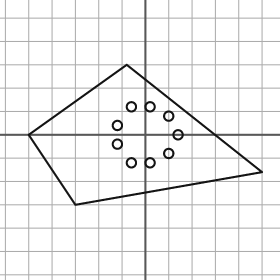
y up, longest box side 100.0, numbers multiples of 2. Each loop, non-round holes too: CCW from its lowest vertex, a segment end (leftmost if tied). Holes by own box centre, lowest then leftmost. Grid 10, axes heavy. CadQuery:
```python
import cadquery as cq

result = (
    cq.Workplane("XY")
    .moveTo(-30.0, -30.0)
    .lineTo(50.0, -16.0)
    .lineTo(-8.0, 30.0)
    .lineTo(-50.0, 0.0)
    .close()
    .moveTo(-6.0, -12.0)
    .circle(2.0)
    .moveTo(2.0, -12.0)
    .circle(2.0)
    .moveTo(10.0, -8.0)
    .circle(2.0)
    .moveTo(-12.0, -4.0)
    .circle(2.0)
    .moveTo(14.0, 0.0)
    .circle(2.0)
    .moveTo(-12.0, 4.0)
    .circle(2.0)
    .moveTo(10.0, 8.0)
    .circle(2.0)
    .moveTo(-6.0, 12.0)
    .circle(2.0)
    .moveTo(2.0, 12.0)
    .circle(2.0)
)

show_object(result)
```